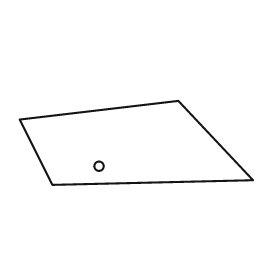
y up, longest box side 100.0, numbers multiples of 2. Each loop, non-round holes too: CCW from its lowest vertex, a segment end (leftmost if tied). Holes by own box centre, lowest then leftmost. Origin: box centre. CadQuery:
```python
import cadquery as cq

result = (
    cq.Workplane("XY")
    .moveTo(-36.0, -18.0)
    .lineTo(50.0, -16.0)
    .lineTo(18.0, 18.0)
    .lineTo(-50.0, 10.0)
    .close()
    .moveTo(-16.0, -10.0)
    .circle(2.0)
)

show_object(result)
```